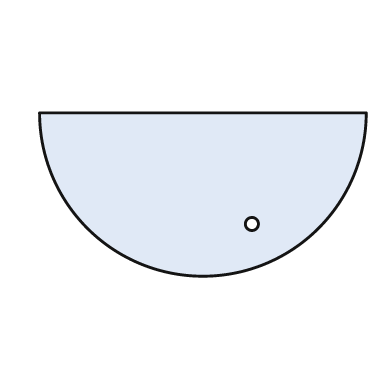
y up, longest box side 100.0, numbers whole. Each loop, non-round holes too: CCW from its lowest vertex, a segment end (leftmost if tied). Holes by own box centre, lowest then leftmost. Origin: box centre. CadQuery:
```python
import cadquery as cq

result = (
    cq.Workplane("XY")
    .moveTo(-50.0, 25.0)
    .threePointArc((0.0, -25.0), (50.0, 25.0))
    .close()
    .moveTo(15.0, -9.0)
    .circle(2.0)
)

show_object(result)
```